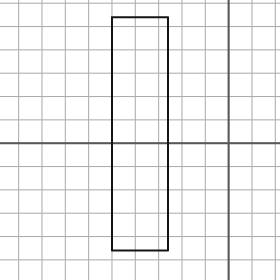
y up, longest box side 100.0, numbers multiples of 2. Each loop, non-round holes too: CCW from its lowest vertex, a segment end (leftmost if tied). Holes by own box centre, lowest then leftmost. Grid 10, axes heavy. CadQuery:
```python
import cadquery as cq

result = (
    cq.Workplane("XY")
    .moveTo(-50.0, -46.0)
    .lineTo(-26.0, -46.0)
    .lineTo(-26.0, 54.0)
    .lineTo(-50.0, 54.0)
    .close()
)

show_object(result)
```